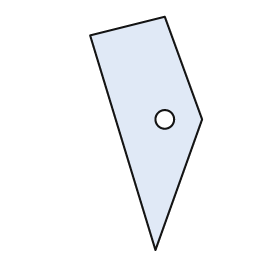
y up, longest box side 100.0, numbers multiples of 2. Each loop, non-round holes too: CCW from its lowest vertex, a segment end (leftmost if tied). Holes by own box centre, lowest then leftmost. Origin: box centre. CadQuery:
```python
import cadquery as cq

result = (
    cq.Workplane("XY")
    .moveTo(4.0, -50.0)
    .lineTo(24.0, 6.0)
    .lineTo(8.0, 50.0)
    .lineTo(-24.0, 42.0)
    .close()
    .moveTo(8.0, 6.0)
    .circle(4.0)
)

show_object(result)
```